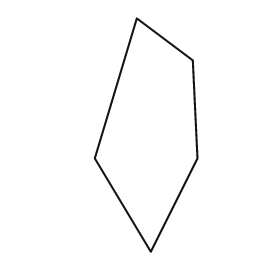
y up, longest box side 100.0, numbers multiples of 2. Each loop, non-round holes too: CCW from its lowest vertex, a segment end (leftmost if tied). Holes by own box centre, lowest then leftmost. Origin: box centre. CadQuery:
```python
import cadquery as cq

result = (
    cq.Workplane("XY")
    .moveTo(2.0, -50.0)
    .lineTo(22.0, -10.0)
    .lineTo(20.0, 32.0)
    .lineTo(-4.0, 50.0)
    .lineTo(-22.0, -10.0)
    .close()
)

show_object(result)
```